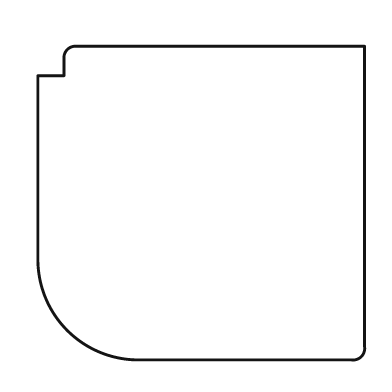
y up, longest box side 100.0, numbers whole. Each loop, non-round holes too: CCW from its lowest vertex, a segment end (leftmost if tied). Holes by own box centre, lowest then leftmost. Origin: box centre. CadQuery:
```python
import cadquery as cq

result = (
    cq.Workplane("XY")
    .moveTo(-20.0, -48.0)
    .lineTo(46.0, -48.0)
    .threePointArc((49.0, -47.0), (50.0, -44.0))
    .lineTo(50.0, 48.0)
    .lineTo(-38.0, 48.0)
    .threePointArc((-41.0, 47.0), (-42.0, 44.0))
    .lineTo(-42.0, 39.0)
    .lineTo(-50.0, 39.0)
    .lineTo(-50.0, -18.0)
    .threePointArc((-41.0, -39.0), (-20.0, -48.0))
    .close()
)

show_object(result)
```